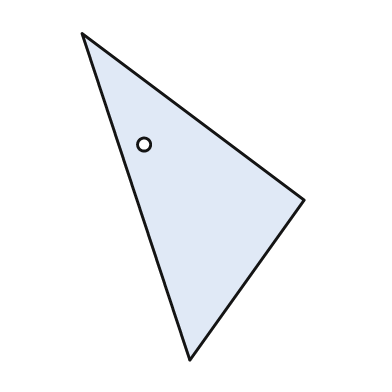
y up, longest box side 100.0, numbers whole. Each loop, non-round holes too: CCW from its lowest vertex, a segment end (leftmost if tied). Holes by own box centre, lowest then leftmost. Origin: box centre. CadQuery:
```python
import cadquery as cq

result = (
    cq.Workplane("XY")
    .moveTo(-1.0, -50.0)
    .lineTo(34.0, -1.0)
    .lineTo(-34.0, 50.0)
    .close()
    .moveTo(-15.0, 16.0)
    .circle(2.0)
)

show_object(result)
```